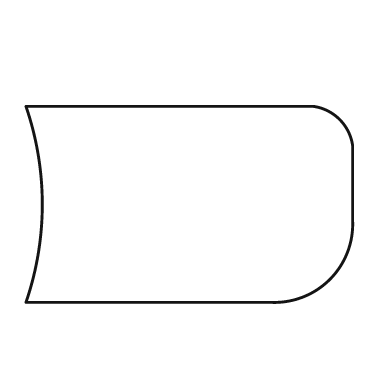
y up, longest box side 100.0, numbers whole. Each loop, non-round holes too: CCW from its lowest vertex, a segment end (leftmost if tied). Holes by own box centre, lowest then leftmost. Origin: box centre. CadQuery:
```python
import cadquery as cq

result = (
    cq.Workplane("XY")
    .moveTo(-50.0, -30.0)
    .lineTo(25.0, -30.0)
    .threePointArc((43.0, -23.0), (50.0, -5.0))
    .lineTo(50.0, 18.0)
    .threePointArc((46.0, 26.0), (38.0, 30.0))
    .lineTo(-50.0, 30.0)
    .threePointArc((-45.0, 0.0), (-50.0, -30.0))
    .close()
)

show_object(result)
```